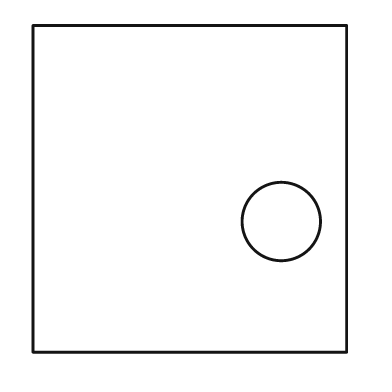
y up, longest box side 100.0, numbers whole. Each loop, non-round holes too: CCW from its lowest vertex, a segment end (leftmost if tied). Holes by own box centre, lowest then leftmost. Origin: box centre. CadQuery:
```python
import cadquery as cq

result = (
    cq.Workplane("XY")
    .moveTo(-48.0, -50.0)
    .lineTo(48.0, -50.0)
    .lineTo(48.0, 50.0)
    .lineTo(-48.0, 50.0)
    .close()
    .moveTo(28.0, -10.0)
    .circle(12.0)
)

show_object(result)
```